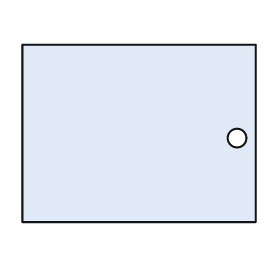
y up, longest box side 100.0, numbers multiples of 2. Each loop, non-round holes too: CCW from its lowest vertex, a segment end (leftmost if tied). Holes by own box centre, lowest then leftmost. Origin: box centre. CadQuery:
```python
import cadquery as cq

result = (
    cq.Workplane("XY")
    .moveTo(-50.0, -38.0)
    .lineTo(50.0, -38.0)
    .lineTo(50.0, 38.0)
    .lineTo(-50.0, 38.0)
    .close()
    .moveTo(42.0, -2.0)
    .circle(4.0)
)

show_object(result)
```